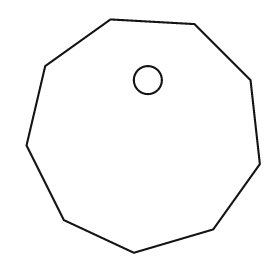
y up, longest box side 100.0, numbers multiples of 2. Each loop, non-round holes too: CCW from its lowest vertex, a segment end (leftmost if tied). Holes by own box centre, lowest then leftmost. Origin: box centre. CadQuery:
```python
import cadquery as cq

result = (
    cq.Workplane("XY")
    .moveTo(-4.0, -50.0)
    .lineTo(30.0, -40.0)
    .lineTo(50.0, -12.0)
    .lineTo(46.0, 24.0)
    .lineTo(22.0, 48.0)
    .lineTo(-14.0, 50.0)
    .lineTo(-42.0, 30.0)
    .lineTo(-50.0, -4.0)
    .lineTo(-34.0, -36.0)
    .close()
    .moveTo(2.0, 24.0)
    .circle(6.0)
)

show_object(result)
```